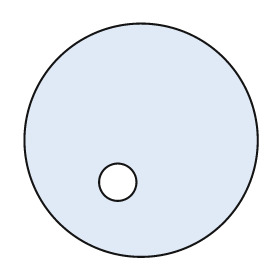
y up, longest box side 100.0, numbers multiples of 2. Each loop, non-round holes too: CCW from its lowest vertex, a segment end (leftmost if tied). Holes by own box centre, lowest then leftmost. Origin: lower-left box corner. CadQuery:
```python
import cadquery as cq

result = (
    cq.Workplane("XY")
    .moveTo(50.0, 50.0)
    .circle(50.0)
    .moveTo(40.0, 32.0)
    .circle(8.0)
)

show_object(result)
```